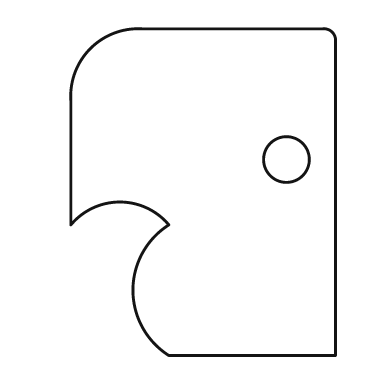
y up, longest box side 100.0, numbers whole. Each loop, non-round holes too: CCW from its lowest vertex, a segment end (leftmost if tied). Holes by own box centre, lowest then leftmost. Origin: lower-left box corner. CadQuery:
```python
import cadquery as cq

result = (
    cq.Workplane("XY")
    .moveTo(30.0, 0.0)
    .lineTo(81.0, 0.0)
    .lineTo(81.0, 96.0)
    .threePointArc((80.0, 99.0), (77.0, 100.0))
    .lineTo(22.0, 100.0)
    .threePointArc((6.0, 94.0), (0.0, 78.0))
    .lineTo(0.0, 40.0)
    .threePointArc((15.0, 47.0), (30.0, 40.0))
    .threePointArc((19.0, 20.0), (30.0, 0.0))
    .close()
    .moveTo(66.0, 60.0)
    .circle(7.0)
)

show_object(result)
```